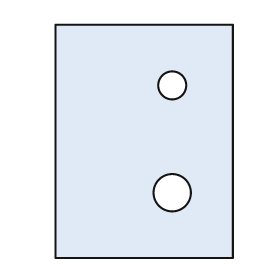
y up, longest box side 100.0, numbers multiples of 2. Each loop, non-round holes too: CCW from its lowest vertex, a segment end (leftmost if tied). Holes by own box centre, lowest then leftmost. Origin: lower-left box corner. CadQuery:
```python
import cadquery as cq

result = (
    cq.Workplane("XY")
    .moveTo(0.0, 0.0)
    .lineTo(76.0, 0.0)
    .lineTo(76.0, 100.0)
    .lineTo(0.0, 100.0)
    .close()
    .moveTo(50.0, 28.0)
    .circle(8.0)
    .moveTo(50.0, 74.0)
    .circle(6.0)
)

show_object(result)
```